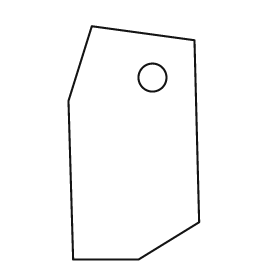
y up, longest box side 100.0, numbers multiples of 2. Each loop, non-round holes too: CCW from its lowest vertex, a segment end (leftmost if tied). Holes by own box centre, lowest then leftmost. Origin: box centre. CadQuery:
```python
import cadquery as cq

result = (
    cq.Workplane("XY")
    .moveTo(-26.0, -50.0)
    .lineTo(2.0, -50.0)
    .lineTo(28.0, -34.0)
    .lineTo(26.0, 44.0)
    .lineTo(-18.0, 50.0)
    .lineTo(-28.0, 18.0)
    .close()
    .moveTo(8.0, 28.0)
    .circle(6.0)
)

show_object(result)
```